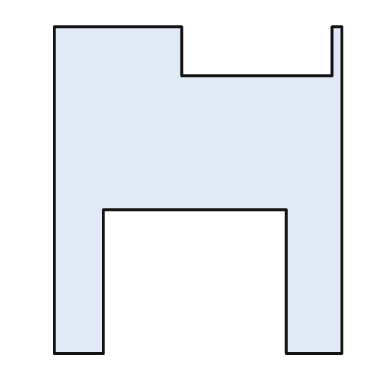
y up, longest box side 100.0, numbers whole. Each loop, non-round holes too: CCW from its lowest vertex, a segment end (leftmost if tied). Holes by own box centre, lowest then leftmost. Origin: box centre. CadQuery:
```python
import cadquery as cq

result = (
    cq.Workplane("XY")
    .moveTo(-44.0, -50.0)
    .lineTo(-29.0, -50.0)
    .lineTo(-29.0, -6.0)
    .lineTo(27.0, -6.0)
    .lineTo(27.0, -50.0)
    .lineTo(44.0, -50.0)
    .lineTo(44.0, 50.0)
    .lineTo(41.0, 50.0)
    .lineTo(41.0, 35.0)
    .lineTo(-5.0, 35.0)
    .lineTo(-5.0, 50.0)
    .lineTo(-44.0, 50.0)
    .close()
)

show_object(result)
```